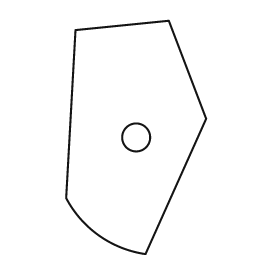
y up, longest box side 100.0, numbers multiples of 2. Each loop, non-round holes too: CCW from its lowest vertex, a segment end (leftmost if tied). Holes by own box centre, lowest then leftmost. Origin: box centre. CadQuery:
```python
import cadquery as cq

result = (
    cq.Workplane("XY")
    .moveTo(4.0, -50.0)
    .lineTo(30.0, 8.0)
    .lineTo(14.0, 50.0)
    .lineTo(-26.0, 46.0)
    .lineTo(-30.0, -26.0)
    .threePointArc((-16.0, -42.0), (4.0, -50.0))
    .close()
    .moveTo(0.0, 0.0)
    .circle(6.0)
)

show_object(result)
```